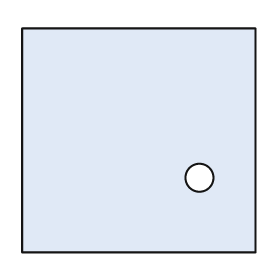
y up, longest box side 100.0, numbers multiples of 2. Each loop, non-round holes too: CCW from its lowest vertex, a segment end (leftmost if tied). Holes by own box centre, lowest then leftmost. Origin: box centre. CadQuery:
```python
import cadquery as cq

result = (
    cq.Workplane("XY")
    .moveTo(-50.0, -48.0)
    .lineTo(50.0, -48.0)
    .lineTo(50.0, 48.0)
    .lineTo(-50.0, 48.0)
    .close()
    .moveTo(26.0, -16.0)
    .circle(6.0)
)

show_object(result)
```